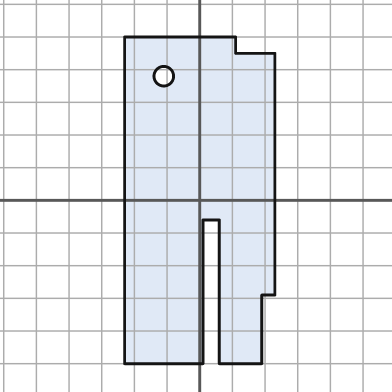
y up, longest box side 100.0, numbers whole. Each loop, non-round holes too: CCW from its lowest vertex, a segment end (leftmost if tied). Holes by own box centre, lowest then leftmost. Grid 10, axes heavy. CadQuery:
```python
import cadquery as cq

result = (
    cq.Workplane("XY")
    .moveTo(-23.0, -50.0)
    .lineTo(1.0, -50.0)
    .lineTo(1.0, -6.0)
    .lineTo(6.0, -6.0)
    .lineTo(6.0, -50.0)
    .lineTo(19.0, -50.0)
    .lineTo(19.0, -29.0)
    .lineTo(23.0, -29.0)
    .lineTo(23.0, 45.0)
    .lineTo(11.0, 45.0)
    .lineTo(11.0, 50.0)
    .lineTo(-23.0, 50.0)
    .close()
    .moveTo(-11.0, 38.0)
    .circle(3.0)
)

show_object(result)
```